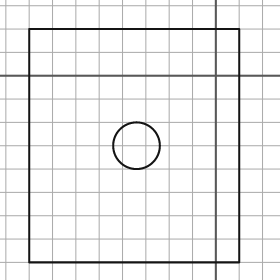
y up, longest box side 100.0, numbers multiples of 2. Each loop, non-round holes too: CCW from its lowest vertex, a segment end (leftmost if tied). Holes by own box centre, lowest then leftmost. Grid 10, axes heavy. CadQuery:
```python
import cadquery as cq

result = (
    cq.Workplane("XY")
    .moveTo(-80.0, -80.0)
    .lineTo(10.0, -80.0)
    .lineTo(10.0, 20.0)
    .lineTo(-80.0, 20.0)
    .close()
    .moveTo(-34.0, -30.0)
    .circle(10.0)
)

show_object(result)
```